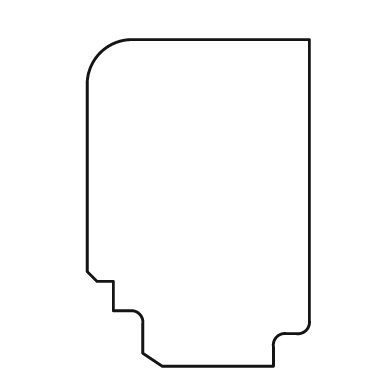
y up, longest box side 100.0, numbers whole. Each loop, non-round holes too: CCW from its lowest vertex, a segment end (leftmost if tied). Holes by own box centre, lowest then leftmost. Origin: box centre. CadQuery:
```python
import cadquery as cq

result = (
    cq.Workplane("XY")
    .moveTo(-11.0, -50.0)
    .lineTo(23.0, -50.0)
    .lineTo(23.0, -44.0)
    .threePointArc((24.0, -41.0), (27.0, -40.0))
    .lineTo(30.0, -40.0)
    .threePointArc((33.0, -39.0), (34.0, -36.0))
    .lineTo(34.0, 50.0)
    .lineTo(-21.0, 50.0)
    .threePointArc((-30.0, 46.0), (-34.0, 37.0))
    .lineTo(-34.0, -21.0)
    .lineTo(-31.0, -24.0)
    .lineTo(-26.0, -24.0)
    .lineTo(-26.0, -33.0)
    .lineTo(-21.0, -33.0)
    .threePointArc((-18.0, -34.0), (-17.0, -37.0))
    .lineTo(-17.0, -46.0)
    .close()
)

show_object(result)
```